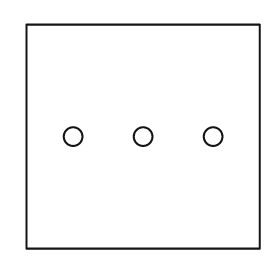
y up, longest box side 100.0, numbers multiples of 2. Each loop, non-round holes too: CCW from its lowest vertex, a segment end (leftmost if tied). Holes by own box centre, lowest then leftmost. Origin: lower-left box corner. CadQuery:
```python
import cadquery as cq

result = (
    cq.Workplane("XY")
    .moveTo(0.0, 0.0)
    .lineTo(100.0, 0.0)
    .lineTo(100.0, 96.0)
    .lineTo(0.0, 96.0)
    .close()
    .moveTo(20.0, 48.0)
    .circle(4.0)
    .moveTo(50.0, 48.0)
    .circle(4.0)
    .moveTo(80.0, 48.0)
    .circle(4.0)
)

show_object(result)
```